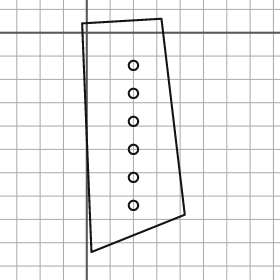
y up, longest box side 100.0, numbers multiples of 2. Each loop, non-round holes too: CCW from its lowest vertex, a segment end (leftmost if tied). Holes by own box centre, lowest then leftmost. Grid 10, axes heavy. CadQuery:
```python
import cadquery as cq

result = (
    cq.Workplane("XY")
    .moveTo(2.0, -94.0)
    .lineTo(42.0, -78.0)
    .lineTo(32.0, 6.0)
    .lineTo(-2.0, 4.0)
    .close()
    .moveTo(20.0, -74.0)
    .circle(2.0)
    .moveTo(20.0, -62.0)
    .circle(2.0)
    .moveTo(20.0, -50.0)
    .circle(2.0)
    .moveTo(20.0, -38.0)
    .circle(2.0)
    .moveTo(20.0, -26.0)
    .circle(2.0)
    .moveTo(20.0, -14.0)
    .circle(2.0)
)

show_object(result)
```